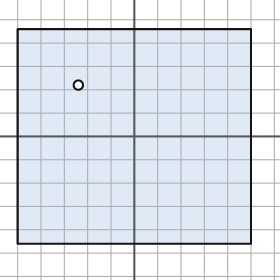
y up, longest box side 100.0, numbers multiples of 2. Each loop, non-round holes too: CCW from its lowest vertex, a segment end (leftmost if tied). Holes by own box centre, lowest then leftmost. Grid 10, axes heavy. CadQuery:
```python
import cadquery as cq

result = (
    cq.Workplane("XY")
    .moveTo(-50.0, -46.0)
    .lineTo(50.0, -46.0)
    .lineTo(50.0, 46.0)
    .lineTo(-50.0, 46.0)
    .close()
    .moveTo(-24.0, 22.0)
    .circle(2.0)
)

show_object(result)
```